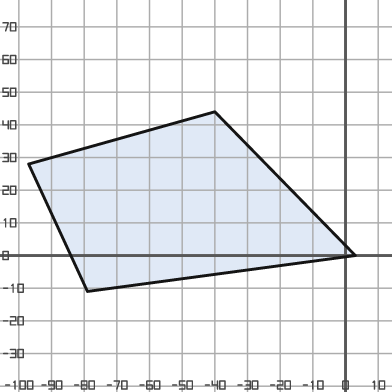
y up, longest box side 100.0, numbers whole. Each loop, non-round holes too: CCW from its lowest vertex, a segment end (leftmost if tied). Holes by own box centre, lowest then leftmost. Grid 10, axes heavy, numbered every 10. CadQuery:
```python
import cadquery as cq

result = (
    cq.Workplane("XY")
    .moveTo(-79.0, -11.0)
    .lineTo(3.0, 0.0)
    .lineTo(-40.0, 44.0)
    .lineTo(-97.0, 28.0)
    .close()
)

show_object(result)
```